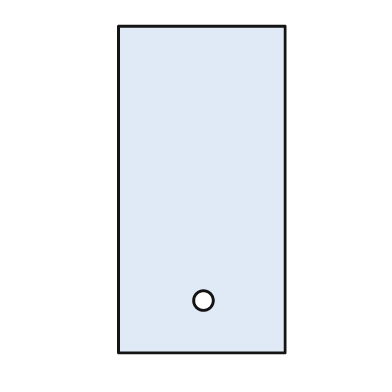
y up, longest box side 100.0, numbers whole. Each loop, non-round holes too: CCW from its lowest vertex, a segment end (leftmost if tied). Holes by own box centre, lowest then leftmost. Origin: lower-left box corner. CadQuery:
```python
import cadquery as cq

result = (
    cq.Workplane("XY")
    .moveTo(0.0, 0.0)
    .lineTo(51.0, 0.0)
    .lineTo(51.0, 100.0)
    .lineTo(0.0, 100.0)
    .close()
    .moveTo(26.0, 16.0)
    .circle(3.0)
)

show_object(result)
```